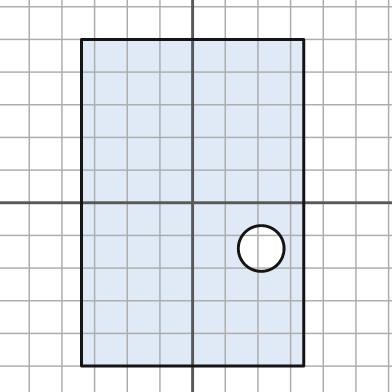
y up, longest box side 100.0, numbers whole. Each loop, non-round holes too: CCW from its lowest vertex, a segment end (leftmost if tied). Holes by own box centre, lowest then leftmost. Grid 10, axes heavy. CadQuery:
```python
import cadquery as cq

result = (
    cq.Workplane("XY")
    .moveTo(-34.0, -50.0)
    .lineTo(34.0, -50.0)
    .lineTo(34.0, 50.0)
    .lineTo(-34.0, 50.0)
    .close()
    .moveTo(21.0, -14.0)
    .circle(7.0)
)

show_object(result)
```